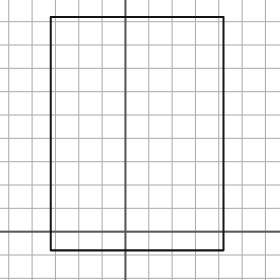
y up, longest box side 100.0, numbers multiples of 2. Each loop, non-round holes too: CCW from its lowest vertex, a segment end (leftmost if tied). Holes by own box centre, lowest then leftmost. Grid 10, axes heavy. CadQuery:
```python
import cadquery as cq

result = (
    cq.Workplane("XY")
    .moveTo(-32.0, -8.0)
    .lineTo(42.0, -8.0)
    .lineTo(42.0, 92.0)
    .lineTo(-32.0, 92.0)
    .close()
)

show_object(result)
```